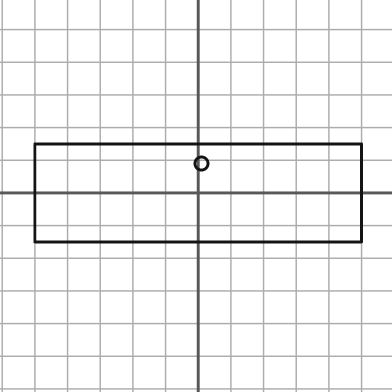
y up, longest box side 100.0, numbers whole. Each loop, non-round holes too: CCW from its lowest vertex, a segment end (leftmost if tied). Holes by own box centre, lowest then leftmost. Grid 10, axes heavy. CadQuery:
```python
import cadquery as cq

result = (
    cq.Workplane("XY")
    .moveTo(-50.0, -15.0)
    .lineTo(50.0, -15.0)
    .lineTo(50.0, 15.0)
    .lineTo(-50.0, 15.0)
    .close()
    .moveTo(1.0, 9.0)
    .circle(2.0)
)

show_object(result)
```